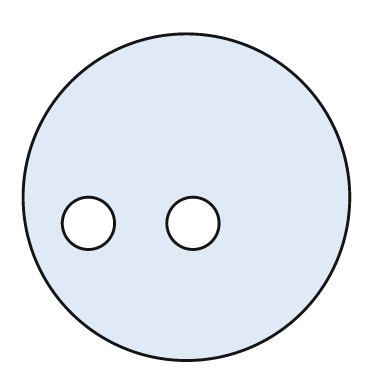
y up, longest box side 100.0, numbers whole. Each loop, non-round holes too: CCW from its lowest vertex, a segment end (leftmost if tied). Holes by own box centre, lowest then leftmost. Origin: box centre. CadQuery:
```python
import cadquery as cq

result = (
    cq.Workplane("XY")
    .moveTo(0.0, 0.0)
    .circle(50.0)
    .moveTo(-30.0, -8.0)
    .circle(8.0)
    .moveTo(2.0, -8.0)
    .circle(8.0)
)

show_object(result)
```